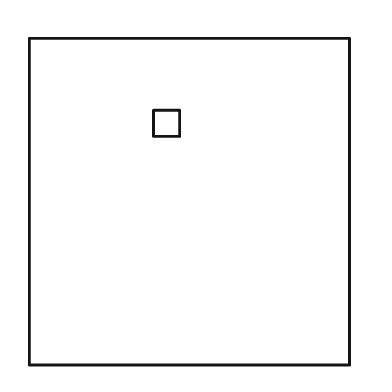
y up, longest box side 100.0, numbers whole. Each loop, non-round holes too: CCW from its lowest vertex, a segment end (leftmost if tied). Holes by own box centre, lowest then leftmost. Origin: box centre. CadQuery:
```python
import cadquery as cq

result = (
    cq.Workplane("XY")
    .moveTo(-49.0, -50.0)
    .lineTo(49.0, -50.0)
    .lineTo(49.0, 50.0)
    .lineTo(-49.0, 50.0)
    .close()
    .moveTo(-11.0, 20.0)
    .lineTo(-3.0, 20.0)
    .lineTo(-3.0, 28.0)
    .lineTo(-11.0, 28.0)
    .close()
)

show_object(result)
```